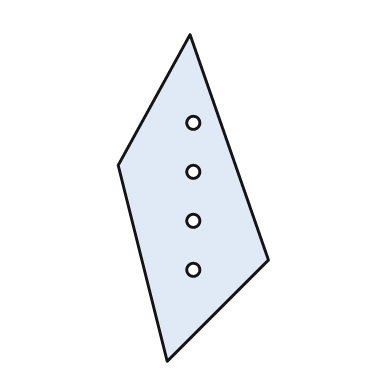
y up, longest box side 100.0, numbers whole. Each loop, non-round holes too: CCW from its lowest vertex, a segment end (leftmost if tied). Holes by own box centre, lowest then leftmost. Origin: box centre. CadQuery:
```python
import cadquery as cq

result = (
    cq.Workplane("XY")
    .moveTo(-8.0, -50.0)
    .lineTo(23.0, -19.0)
    .lineTo(-1.0, 50.0)
    .lineTo(-23.0, 10.0)
    .close()
    .moveTo(0.0, -22.0)
    .circle(2.0)
    .moveTo(0.0, -7.0)
    .circle(2.0)
    .moveTo(0.0, 8.0)
    .circle(2.0)
    .moveTo(0.0, 23.0)
    .circle(2.0)
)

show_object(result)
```